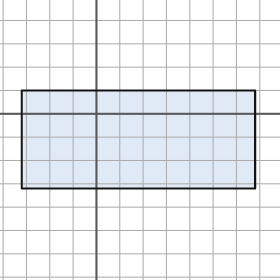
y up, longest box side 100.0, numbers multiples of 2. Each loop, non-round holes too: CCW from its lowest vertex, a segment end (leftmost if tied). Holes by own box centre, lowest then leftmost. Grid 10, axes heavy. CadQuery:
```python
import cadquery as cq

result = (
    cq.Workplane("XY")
    .moveTo(-32.0, -32.0)
    .lineTo(68.0, -32.0)
    .lineTo(68.0, 10.0)
    .lineTo(-32.0, 10.0)
    .close()
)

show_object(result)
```